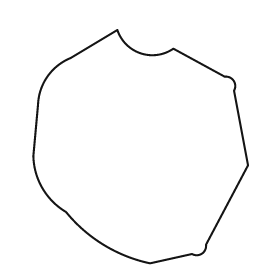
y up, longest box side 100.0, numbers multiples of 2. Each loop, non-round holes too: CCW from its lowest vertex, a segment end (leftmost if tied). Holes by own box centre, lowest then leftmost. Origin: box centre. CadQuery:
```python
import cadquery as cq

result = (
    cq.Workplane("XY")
    .moveTo(4.0, -50.0)
    .lineTo(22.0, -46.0)
    .threePointArc((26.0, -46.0), (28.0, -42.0))
    .lineTo(46.0, -8.0)
    .lineTo(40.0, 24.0)
    .threePointArc((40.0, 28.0), (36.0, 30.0))
    .lineTo(14.0, 42.0)
    .threePointArc((0.0, 40.0), (-10.0, 50.0))
    .lineTo(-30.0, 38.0)
    .threePointArc((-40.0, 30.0), (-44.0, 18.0))
    .lineTo(-46.0, -4.0)
    .threePointArc((-42.0, -18.0), (-32.0, -28.0))
    .threePointArc((-16.0, -42.0), (4.0, -50.0))
    .close()
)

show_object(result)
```